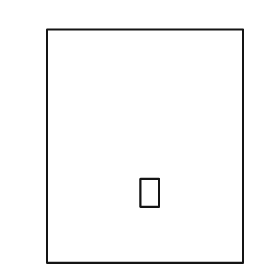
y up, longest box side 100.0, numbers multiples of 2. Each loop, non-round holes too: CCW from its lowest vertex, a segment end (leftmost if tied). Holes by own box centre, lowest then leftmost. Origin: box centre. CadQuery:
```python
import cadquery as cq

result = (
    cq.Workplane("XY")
    .moveTo(-42.0, -50.0)
    .lineTo(42.0, -50.0)
    .lineTo(42.0, 50.0)
    .lineTo(-42.0, 50.0)
    .close()
    .moveTo(-2.0, -26.0)
    .lineTo(6.0, -26.0)
    .lineTo(6.0, -14.0)
    .lineTo(-2.0, -14.0)
    .close()
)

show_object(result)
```